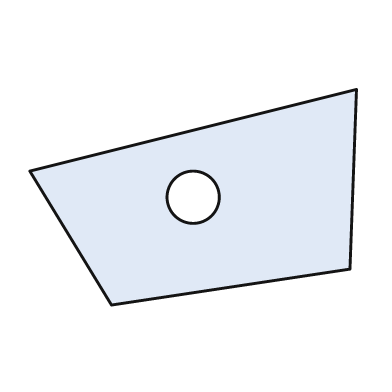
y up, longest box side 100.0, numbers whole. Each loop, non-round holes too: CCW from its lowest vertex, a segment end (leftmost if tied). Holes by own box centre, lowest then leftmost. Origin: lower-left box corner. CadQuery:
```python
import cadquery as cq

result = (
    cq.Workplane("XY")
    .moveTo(25.0, 0.0)
    .lineTo(98.0, 11.0)
    .lineTo(100.0, 66.0)
    .lineTo(0.0, 41.0)
    .close()
    .moveTo(50.0, 33.0)
    .circle(8.0)
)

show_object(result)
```